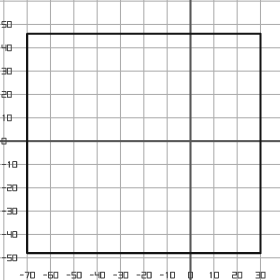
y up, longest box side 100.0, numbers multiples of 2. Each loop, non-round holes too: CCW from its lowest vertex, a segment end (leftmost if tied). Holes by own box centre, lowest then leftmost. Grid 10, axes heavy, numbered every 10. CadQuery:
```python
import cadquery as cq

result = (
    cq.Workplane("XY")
    .moveTo(-70.0, -48.0)
    .lineTo(30.0, -48.0)
    .lineTo(30.0, 46.0)
    .lineTo(-70.0, 46.0)
    .close()
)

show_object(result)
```